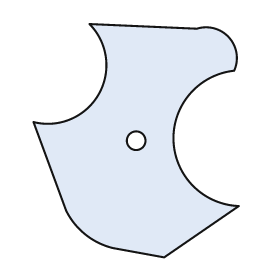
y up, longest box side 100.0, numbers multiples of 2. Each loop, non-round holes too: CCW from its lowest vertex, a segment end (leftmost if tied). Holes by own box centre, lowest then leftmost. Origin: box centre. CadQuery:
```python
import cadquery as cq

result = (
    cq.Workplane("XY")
    .moveTo(12.0, -50.0)
    .lineTo(44.0, -28.0)
    .threePointArc((16.0, 0.0), (42.0, 30.0))
    .threePointArc((40.0, 44.0), (26.0, 48.0))
    .lineTo(-20.0, 50.0)
    .threePointArc((-16.0, 20.0), (-44.0, 8.0))
    .lineTo(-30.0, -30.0)
    .threePointArc((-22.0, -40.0), (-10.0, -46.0))
    .close()
    .moveTo(0.0, 0.0)
    .circle(4.0)
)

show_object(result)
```